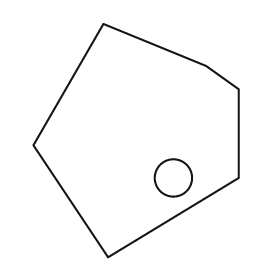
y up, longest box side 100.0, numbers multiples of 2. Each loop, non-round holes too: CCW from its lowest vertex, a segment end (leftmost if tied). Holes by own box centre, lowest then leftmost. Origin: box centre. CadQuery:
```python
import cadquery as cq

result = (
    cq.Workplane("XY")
    .moveTo(-12.0, -50.0)
    .lineTo(44.0, -16.0)
    .lineTo(44.0, 22.0)
    .lineTo(30.0, 32.0)
    .lineTo(-14.0, 50.0)
    .lineTo(-44.0, -2.0)
    .close()
    .moveTo(16.0, -16.0)
    .circle(8.0)
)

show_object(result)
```